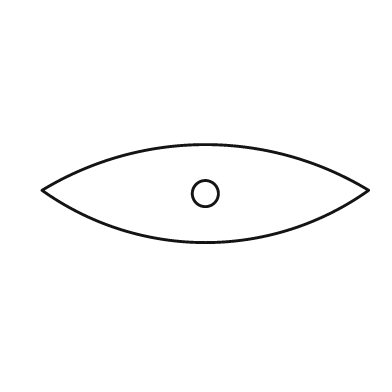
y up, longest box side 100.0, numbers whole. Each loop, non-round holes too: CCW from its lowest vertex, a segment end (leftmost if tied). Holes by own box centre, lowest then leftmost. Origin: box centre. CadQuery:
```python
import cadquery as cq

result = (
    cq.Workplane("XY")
    .moveTo(-50.0, 1.0)
    .threePointArc((0.0, -15.0), (50.0, 1.0))
    .threePointArc((0.0, 15.0), (-50.0, 1.0))
    .close()
    .moveTo(0.0, 0.0)
    .circle(4.0)
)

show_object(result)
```